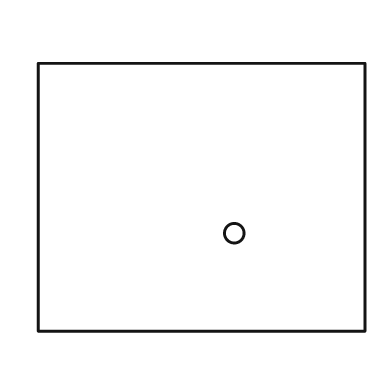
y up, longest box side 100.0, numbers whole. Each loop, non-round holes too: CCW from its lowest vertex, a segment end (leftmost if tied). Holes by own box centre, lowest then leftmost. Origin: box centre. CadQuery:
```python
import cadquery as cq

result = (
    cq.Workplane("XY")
    .moveTo(-50.0, -41.0)
    .lineTo(50.0, -41.0)
    .lineTo(50.0, 41.0)
    .lineTo(-50.0, 41.0)
    .close()
    .moveTo(10.0, -11.0)
    .circle(3.0)
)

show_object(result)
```